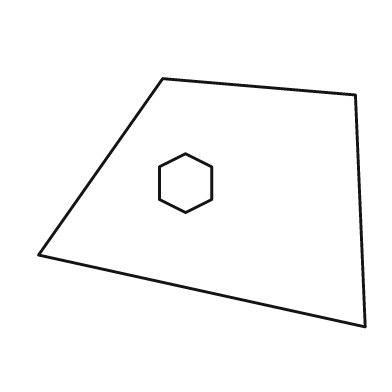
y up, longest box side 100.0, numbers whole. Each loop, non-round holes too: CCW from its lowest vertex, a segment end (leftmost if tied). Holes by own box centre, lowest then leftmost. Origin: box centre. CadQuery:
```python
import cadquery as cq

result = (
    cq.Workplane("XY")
    .moveTo(50.0, -38.0)
    .lineTo(47.0, 33.0)
    .lineTo(-12.0, 38.0)
    .lineTo(-50.0, -16.0)
    .close()
    .moveTo(-5.0, -3.0)
    .lineTo(3.0, 1.0)
    .lineTo(3.0, 11.0)
    .lineTo(-5.0, 15.0)
    .lineTo(-13.0, 11.0)
    .lineTo(-13.0, 1.0)
    .close()
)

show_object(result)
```